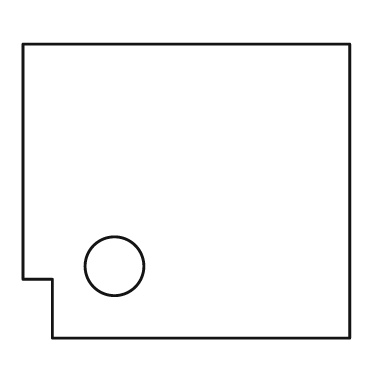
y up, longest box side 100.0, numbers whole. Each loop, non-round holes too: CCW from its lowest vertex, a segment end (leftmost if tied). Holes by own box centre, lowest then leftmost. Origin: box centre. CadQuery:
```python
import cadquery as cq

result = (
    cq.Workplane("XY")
    .moveTo(-41.0, -45.0)
    .lineTo(50.0, -45.0)
    .lineTo(50.0, 45.0)
    .lineTo(-50.0, 45.0)
    .lineTo(-50.0, -27.0)
    .lineTo(-41.0, -27.0)
    .close()
    .moveTo(-22.0, -23.0)
    .circle(9.0)
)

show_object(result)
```